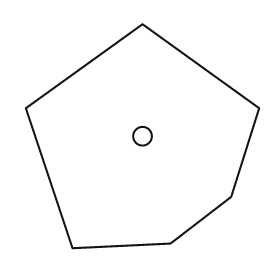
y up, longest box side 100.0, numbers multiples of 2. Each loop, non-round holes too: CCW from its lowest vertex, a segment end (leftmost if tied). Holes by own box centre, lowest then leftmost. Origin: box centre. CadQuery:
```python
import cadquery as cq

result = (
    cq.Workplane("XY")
    .moveTo(-30.0, -48.0)
    .lineTo(12.0, -46.0)
    .lineTo(38.0, -26.0)
    .lineTo(50.0, 12.0)
    .lineTo(0.0, 48.0)
    .lineTo(-50.0, 12.0)
    .close()
    .moveTo(0.0, 0.0)
    .circle(4.0)
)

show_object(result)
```